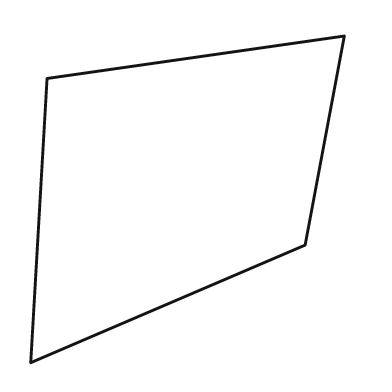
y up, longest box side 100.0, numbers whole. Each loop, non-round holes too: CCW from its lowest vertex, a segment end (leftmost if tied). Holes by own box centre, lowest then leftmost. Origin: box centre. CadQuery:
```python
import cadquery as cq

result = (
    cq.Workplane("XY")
    .moveTo(-48.0, -50.0)
    .lineTo(36.0, -14.0)
    .lineTo(48.0, 50.0)
    .lineTo(-43.0, 37.0)
    .close()
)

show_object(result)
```